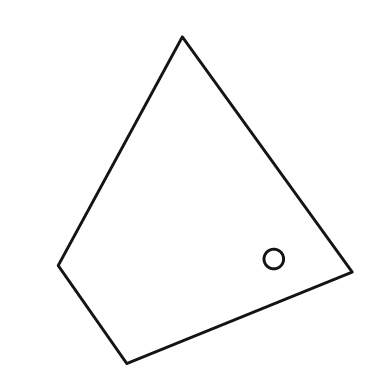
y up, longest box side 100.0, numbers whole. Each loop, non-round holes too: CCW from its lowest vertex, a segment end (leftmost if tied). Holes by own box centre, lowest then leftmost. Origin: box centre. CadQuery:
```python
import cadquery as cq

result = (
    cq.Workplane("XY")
    .moveTo(-24.0, -50.0)
    .lineTo(45.0, -22.0)
    .lineTo(-7.0, 50.0)
    .lineTo(-45.0, -20.0)
    .close()
    .moveTo(21.0, -18.0)
    .circle(3.0)
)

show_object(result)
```